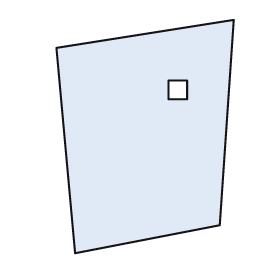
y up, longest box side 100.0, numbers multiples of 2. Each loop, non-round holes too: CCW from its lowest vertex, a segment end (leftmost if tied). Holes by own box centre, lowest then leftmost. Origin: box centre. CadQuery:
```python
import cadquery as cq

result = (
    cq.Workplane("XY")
    .moveTo(-30.0, -50.0)
    .lineTo(32.0, -38.0)
    .lineTo(38.0, 50.0)
    .lineTo(-38.0, 38.0)
    .close()
    .moveTo(10.0, 16.0)
    .lineTo(18.0, 16.0)
    .lineTo(18.0, 24.0)
    .lineTo(10.0, 24.0)
    .close()
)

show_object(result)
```